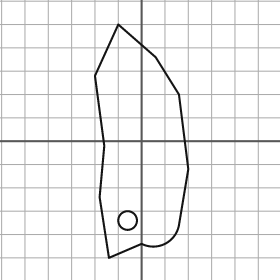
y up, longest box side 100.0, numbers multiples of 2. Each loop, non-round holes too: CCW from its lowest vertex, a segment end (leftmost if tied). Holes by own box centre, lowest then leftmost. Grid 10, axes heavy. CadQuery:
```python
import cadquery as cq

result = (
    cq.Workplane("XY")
    .moveTo(-14.0, -50.0)
    .lineTo(0.0, -44.0)
    .threePointArc((10.0, -44.0), (16.0, -36.0))
    .lineTo(20.0, -12.0)
    .lineTo(16.0, 20.0)
    .lineTo(6.0, 36.0)
    .lineTo(-10.0, 50.0)
    .lineTo(-20.0, 28.0)
    .lineTo(-16.0, -2.0)
    .lineTo(-18.0, -24.0)
    .close()
    .moveTo(-6.0, -34.0)
    .circle(4.0)
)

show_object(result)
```